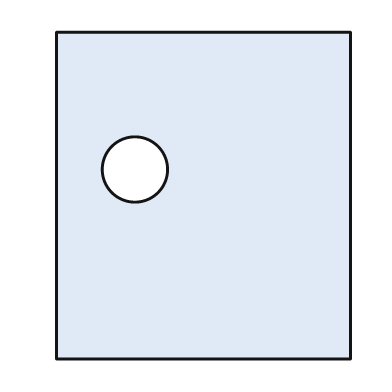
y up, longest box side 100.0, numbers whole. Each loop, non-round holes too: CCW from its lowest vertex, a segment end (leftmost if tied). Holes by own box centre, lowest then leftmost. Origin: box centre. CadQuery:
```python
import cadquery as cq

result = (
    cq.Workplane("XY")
    .moveTo(-45.0, -50.0)
    .lineTo(45.0, -50.0)
    .lineTo(45.0, 50.0)
    .lineTo(-45.0, 50.0)
    .close()
    .moveTo(-21.0, 8.0)
    .circle(10.0)
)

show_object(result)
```